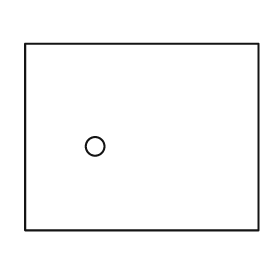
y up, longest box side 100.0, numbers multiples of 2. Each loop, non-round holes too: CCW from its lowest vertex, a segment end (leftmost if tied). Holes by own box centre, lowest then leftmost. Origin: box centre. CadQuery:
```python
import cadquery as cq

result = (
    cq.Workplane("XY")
    .moveTo(-50.0, -40.0)
    .lineTo(50.0, -40.0)
    .lineTo(50.0, 40.0)
    .lineTo(-50.0, 40.0)
    .close()
    .moveTo(-20.0, -4.0)
    .circle(4.0)
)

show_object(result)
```